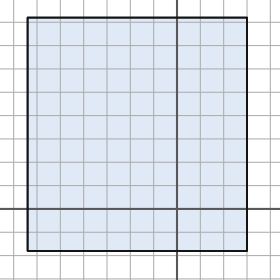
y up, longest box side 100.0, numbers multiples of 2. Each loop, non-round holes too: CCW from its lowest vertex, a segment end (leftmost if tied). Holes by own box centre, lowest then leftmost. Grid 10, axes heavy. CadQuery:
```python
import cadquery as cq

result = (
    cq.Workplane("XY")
    .moveTo(-64.0, -18.0)
    .lineTo(30.0, -18.0)
    .lineTo(30.0, 82.0)
    .lineTo(-64.0, 82.0)
    .close()
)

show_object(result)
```